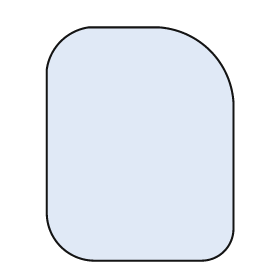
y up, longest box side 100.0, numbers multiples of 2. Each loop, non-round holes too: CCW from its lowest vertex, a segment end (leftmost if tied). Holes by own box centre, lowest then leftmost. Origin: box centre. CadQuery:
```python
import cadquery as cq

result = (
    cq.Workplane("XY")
    .moveTo(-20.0, -50.0)
    .lineTo(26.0, -50.0)
    .threePointArc((36.0, -46.0), (40.0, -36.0))
    .lineTo(40.0, 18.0)
    .threePointArc((30.0, 40.0), (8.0, 50.0))
    .lineTo(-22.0, 50.0)
    .threePointArc((-34.0, 44.0), (-40.0, 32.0))
    .lineTo(-40.0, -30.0)
    .threePointArc((-34.0, -44.0), (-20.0, -50.0))
    .close()
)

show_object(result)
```